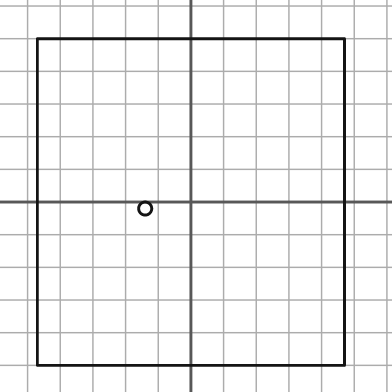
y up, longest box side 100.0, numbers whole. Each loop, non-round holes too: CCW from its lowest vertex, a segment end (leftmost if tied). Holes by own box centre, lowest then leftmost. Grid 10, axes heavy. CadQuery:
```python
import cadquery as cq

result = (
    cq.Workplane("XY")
    .moveTo(-47.0, -50.0)
    .lineTo(47.0, -50.0)
    .lineTo(47.0, 50.0)
    .lineTo(-47.0, 50.0)
    .close()
    .moveTo(-14.0, -2.0)
    .circle(2.0)
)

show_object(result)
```